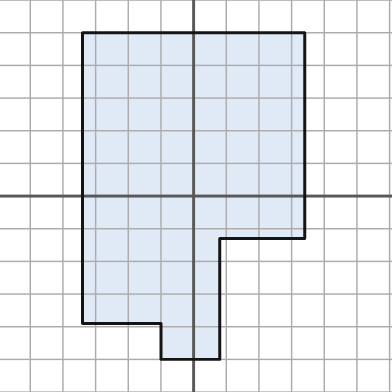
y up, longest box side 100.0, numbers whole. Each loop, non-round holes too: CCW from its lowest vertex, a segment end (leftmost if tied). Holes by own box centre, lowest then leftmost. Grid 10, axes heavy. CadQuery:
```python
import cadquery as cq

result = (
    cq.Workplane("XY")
    .moveTo(-10.0, -50.0)
    .lineTo(8.0, -50.0)
    .lineTo(8.0, -13.0)
    .lineTo(34.0, -13.0)
    .lineTo(34.0, 50.0)
    .lineTo(-34.0, 50.0)
    .lineTo(-34.0, -39.0)
    .lineTo(-10.0, -39.0)
    .close()
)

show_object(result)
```